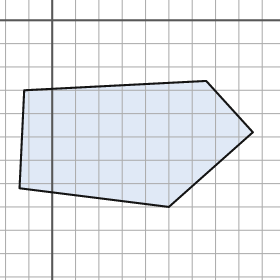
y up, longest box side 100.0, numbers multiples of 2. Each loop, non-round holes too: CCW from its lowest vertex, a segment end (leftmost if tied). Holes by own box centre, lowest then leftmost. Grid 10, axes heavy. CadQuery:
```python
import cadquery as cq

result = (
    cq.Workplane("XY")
    .moveTo(50.0, -80.0)
    .lineTo(86.0, -48.0)
    .lineTo(66.0, -26.0)
    .lineTo(-12.0, -30.0)
    .lineTo(-14.0, -72.0)
    .close()
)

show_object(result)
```